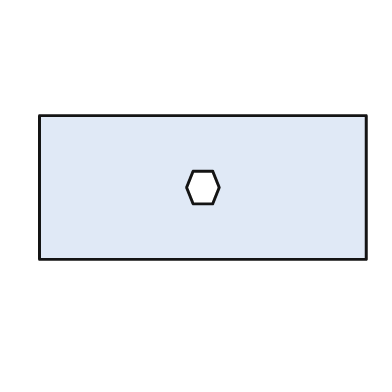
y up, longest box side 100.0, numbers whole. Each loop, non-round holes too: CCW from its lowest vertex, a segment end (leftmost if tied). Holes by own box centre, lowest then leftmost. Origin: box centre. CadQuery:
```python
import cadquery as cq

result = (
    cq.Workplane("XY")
    .moveTo(-50.0, -22.0)
    .lineTo(50.0, -22.0)
    .lineTo(50.0, 22.0)
    .lineTo(-50.0, 22.0)
    .close()
    .moveTo(-3.0, -5.0)
    .lineTo(3.0, -5.0)
    .lineTo(5.0, 0.0)
    .lineTo(3.0, 5.0)
    .lineTo(-3.0, 5.0)
    .lineTo(-5.0, 0.0)
    .close()
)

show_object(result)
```